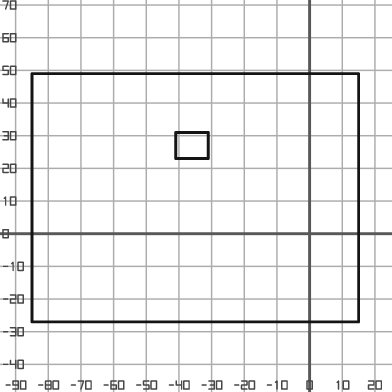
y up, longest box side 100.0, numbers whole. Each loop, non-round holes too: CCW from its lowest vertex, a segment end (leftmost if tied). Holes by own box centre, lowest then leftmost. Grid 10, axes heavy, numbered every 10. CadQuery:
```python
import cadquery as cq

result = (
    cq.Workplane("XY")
    .moveTo(-85.0, -27.0)
    .lineTo(15.0, -27.0)
    .lineTo(15.0, 49.0)
    .lineTo(-85.0, 49.0)
    .close()
    .moveTo(-41.0, 23.0)
    .lineTo(-31.0, 23.0)
    .lineTo(-31.0, 31.0)
    .lineTo(-41.0, 31.0)
    .close()
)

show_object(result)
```